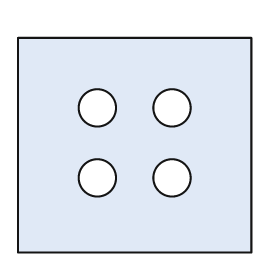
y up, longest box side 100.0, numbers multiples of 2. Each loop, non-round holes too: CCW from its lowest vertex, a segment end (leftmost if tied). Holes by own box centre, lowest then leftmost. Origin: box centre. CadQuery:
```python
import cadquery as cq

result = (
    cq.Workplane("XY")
    .moveTo(-50.0, -46.0)
    .lineTo(50.0, -46.0)
    .lineTo(50.0, 46.0)
    .lineTo(-50.0, 46.0)
    .close()
    .moveTo(-16.0, -14.0)
    .circle(8.0)
    .moveTo(16.0, -14.0)
    .circle(8.0)
    .moveTo(-16.0, 16.0)
    .circle(8.0)
    .moveTo(16.0, 16.0)
    .circle(8.0)
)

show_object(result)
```